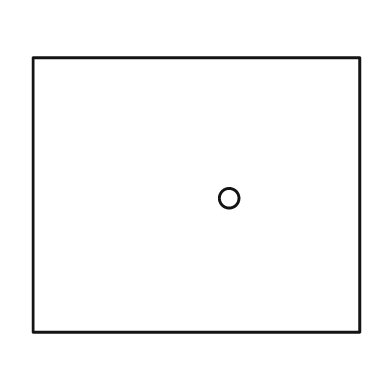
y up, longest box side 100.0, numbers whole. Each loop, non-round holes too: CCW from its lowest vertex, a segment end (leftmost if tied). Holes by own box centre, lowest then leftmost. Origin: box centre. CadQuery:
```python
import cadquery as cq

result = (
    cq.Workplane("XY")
    .moveTo(-50.0, -42.0)
    .lineTo(50.0, -42.0)
    .lineTo(50.0, 42.0)
    .lineTo(-50.0, 42.0)
    .close()
    .moveTo(10.0, -1.0)
    .circle(3.0)
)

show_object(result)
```